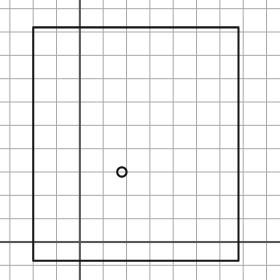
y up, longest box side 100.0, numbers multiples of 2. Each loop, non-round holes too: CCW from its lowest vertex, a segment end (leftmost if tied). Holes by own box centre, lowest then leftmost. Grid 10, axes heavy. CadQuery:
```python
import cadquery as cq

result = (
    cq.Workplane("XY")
    .moveTo(-20.0, -8.0)
    .lineTo(68.0, -8.0)
    .lineTo(68.0, 92.0)
    .lineTo(-20.0, 92.0)
    .close()
    .moveTo(18.0, 30.0)
    .circle(2.0)
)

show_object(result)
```